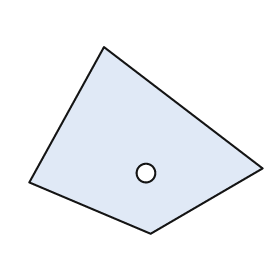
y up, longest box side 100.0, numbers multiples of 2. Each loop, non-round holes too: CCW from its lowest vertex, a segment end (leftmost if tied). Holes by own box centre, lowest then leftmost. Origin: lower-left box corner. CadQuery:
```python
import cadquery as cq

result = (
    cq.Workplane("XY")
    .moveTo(52.0, 0.0)
    .lineTo(100.0, 28.0)
    .lineTo(32.0, 80.0)
    .lineTo(0.0, 22.0)
    .close()
    .moveTo(50.0, 26.0)
    .circle(4.0)
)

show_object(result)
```